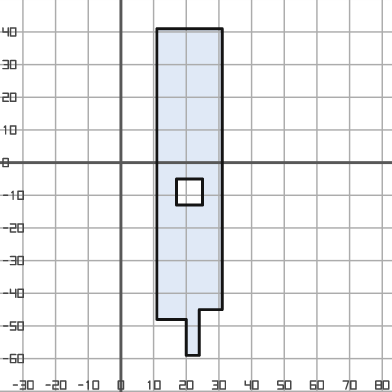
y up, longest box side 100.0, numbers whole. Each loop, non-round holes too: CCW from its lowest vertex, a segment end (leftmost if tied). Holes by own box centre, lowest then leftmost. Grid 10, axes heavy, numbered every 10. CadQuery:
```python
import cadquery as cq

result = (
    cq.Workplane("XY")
    .moveTo(20.0, -59.0)
    .lineTo(24.0, -59.0)
    .lineTo(24.0, -45.0)
    .lineTo(31.0, -45.0)
    .lineTo(31.0, 41.0)
    .lineTo(11.0, 41.0)
    .lineTo(11.0, -48.0)
    .lineTo(20.0, -48.0)
    .close()
    .moveTo(17.0, -13.0)
    .lineTo(25.0, -13.0)
    .lineTo(25.0, -5.0)
    .lineTo(17.0, -5.0)
    .close()
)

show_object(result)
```